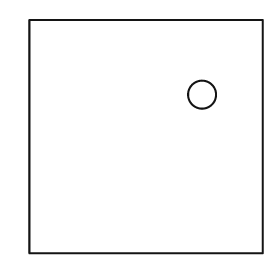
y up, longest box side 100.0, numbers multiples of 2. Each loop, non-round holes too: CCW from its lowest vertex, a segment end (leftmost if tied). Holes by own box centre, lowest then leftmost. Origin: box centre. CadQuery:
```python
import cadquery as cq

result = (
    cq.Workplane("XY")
    .moveTo(-50.0, -50.0)
    .lineTo(50.0, -50.0)
    .lineTo(50.0, 50.0)
    .lineTo(-50.0, 50.0)
    .close()
    .moveTo(24.0, 18.0)
    .circle(6.0)
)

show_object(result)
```